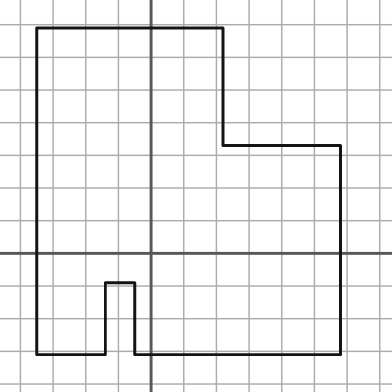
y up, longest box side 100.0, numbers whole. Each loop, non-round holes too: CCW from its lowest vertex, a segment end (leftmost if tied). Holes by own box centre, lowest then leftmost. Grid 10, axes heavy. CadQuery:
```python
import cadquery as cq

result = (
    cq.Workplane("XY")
    .moveTo(-35.0, -31.0)
    .lineTo(-14.0, -31.0)
    .lineTo(-14.0, -9.0)
    .lineTo(-5.0, -9.0)
    .lineTo(-5.0, -31.0)
    .lineTo(58.0, -31.0)
    .lineTo(58.0, 33.0)
    .lineTo(22.0, 33.0)
    .lineTo(22.0, 69.0)
    .lineTo(-35.0, 69.0)
    .close()
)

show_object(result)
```